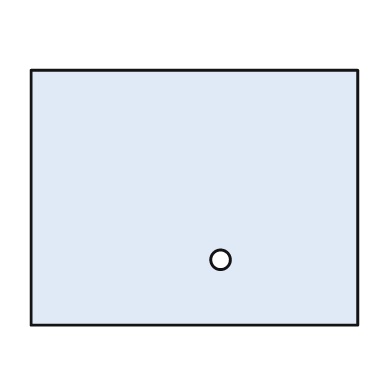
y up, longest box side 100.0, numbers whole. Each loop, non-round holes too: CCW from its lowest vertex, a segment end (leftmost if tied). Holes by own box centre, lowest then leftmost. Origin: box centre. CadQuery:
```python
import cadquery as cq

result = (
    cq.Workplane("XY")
    .moveTo(-50.0, -39.0)
    .lineTo(50.0, -39.0)
    .lineTo(50.0, 39.0)
    .lineTo(-50.0, 39.0)
    .close()
    .moveTo(8.0, -19.0)
    .circle(3.0)
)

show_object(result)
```